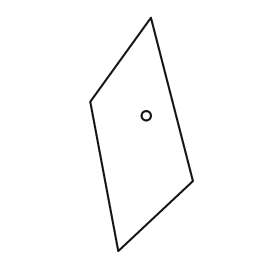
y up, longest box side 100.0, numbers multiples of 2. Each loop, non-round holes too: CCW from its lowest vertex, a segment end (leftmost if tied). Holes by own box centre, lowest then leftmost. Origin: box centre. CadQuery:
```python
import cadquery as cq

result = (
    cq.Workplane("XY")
    .moveTo(-10.0, -50.0)
    .lineTo(22.0, -20.0)
    .lineTo(4.0, 50.0)
    .lineTo(-22.0, 14.0)
    .close()
    .moveTo(2.0, 8.0)
    .circle(2.0)
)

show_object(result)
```